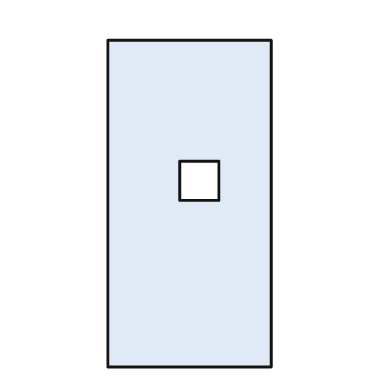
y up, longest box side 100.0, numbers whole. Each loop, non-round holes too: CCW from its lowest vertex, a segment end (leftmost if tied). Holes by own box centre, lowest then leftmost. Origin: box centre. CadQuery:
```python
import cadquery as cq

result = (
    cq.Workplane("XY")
    .moveTo(-25.0, -50.0)
    .lineTo(25.0, -50.0)
    .lineTo(25.0, 50.0)
    .lineTo(-25.0, 50.0)
    .close()
    .moveTo(-3.0, 1.0)
    .lineTo(9.0, 1.0)
    .lineTo(9.0, 13.0)
    .lineTo(-3.0, 13.0)
    .close()
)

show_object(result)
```